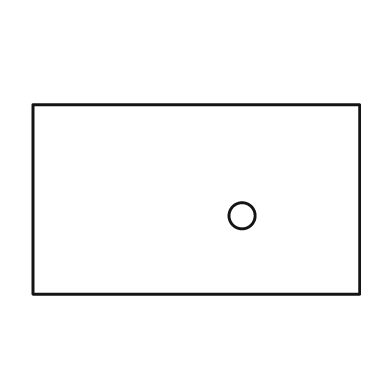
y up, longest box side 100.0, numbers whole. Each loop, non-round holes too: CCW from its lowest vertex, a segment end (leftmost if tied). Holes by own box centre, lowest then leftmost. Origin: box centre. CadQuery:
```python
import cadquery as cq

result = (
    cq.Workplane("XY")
    .moveTo(-50.0, -29.0)
    .lineTo(50.0, -29.0)
    .lineTo(50.0, 29.0)
    .lineTo(-50.0, 29.0)
    .close()
    .moveTo(14.0, -5.0)
    .circle(4.0)
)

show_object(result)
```